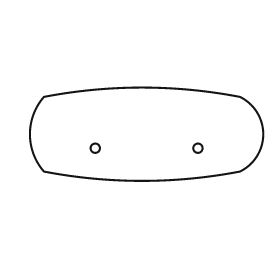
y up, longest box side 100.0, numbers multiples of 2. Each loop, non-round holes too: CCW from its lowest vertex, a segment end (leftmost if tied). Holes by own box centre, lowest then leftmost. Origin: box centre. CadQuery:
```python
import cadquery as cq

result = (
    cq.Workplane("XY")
    .moveTo(-44.0, -16.0)
    .threePointArc((-2.0, -20.0), (40.0, -16.0))
    .threePointArc((50.0, 0.0), (40.0, 16.0))
    .threePointArc((-2.0, 20.0), (-44.0, 16.0))
    .threePointArc((-50.0, 0.0), (-44.0, -16.0))
    .close()
    .moveTo(-22.0, -6.0)
    .circle(2.0)
    .moveTo(22.0, -6.0)
    .circle(2.0)
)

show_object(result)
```